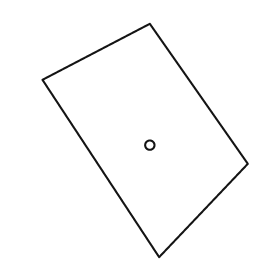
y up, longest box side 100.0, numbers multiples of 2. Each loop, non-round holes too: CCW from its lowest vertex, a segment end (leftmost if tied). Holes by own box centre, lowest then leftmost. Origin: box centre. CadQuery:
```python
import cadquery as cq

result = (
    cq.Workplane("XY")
    .moveTo(6.0, -50.0)
    .lineTo(44.0, -10.0)
    .lineTo(2.0, 50.0)
    .lineTo(-44.0, 26.0)
    .close()
    .moveTo(2.0, -2.0)
    .circle(2.0)
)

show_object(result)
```